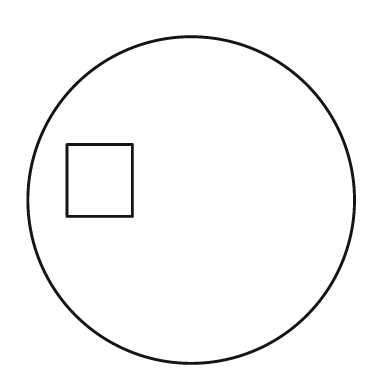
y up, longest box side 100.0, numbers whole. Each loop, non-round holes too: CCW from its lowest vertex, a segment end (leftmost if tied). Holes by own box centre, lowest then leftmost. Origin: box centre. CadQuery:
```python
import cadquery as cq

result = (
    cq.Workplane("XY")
    .moveTo(0.0, 0.0)
    .circle(50.0)
    .moveTo(-38.0, -5.0)
    .lineTo(-18.0, -5.0)
    .lineTo(-18.0, 17.0)
    .lineTo(-38.0, 17.0)
    .close()
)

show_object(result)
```